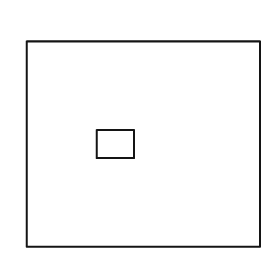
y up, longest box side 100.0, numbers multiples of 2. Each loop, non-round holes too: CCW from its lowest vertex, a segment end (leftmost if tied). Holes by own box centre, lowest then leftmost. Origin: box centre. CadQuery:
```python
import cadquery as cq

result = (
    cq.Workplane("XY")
    .moveTo(-50.0, -44.0)
    .lineTo(50.0, -44.0)
    .lineTo(50.0, 44.0)
    .lineTo(-50.0, 44.0)
    .close()
    .moveTo(-20.0, -6.0)
    .lineTo(-4.0, -6.0)
    .lineTo(-4.0, 6.0)
    .lineTo(-20.0, 6.0)
    .close()
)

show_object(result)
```